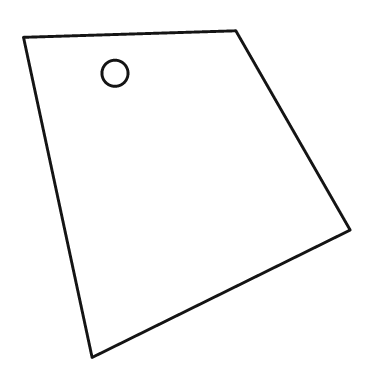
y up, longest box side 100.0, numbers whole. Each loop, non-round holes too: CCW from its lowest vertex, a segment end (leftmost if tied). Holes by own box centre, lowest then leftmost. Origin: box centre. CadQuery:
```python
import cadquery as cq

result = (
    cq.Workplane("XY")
    .moveTo(-29.0, -50.0)
    .lineTo(50.0, -11.0)
    .lineTo(15.0, 50.0)
    .lineTo(-50.0, 48.0)
    .close()
    .moveTo(-22.0, 37.0)
    .circle(4.0)
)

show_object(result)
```